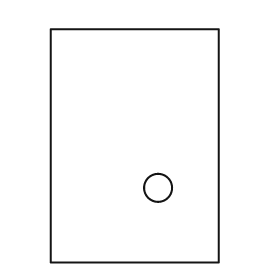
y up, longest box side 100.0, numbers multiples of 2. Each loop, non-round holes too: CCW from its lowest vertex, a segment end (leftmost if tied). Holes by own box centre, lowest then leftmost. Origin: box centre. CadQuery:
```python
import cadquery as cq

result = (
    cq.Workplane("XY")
    .moveTo(-36.0, -50.0)
    .lineTo(36.0, -50.0)
    .lineTo(36.0, 50.0)
    .lineTo(-36.0, 50.0)
    .close()
    .moveTo(10.0, -18.0)
    .circle(6.0)
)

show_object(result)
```